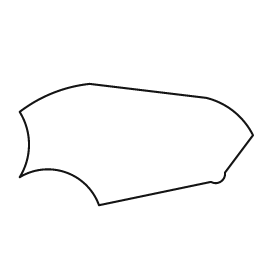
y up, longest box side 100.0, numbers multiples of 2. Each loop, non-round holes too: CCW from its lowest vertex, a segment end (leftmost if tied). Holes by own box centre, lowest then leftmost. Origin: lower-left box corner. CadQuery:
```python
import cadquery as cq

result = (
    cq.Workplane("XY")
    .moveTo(34.0, 0.0)
    .lineTo(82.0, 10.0)
    .threePointArc((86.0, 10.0), (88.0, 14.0))
    .lineTo(100.0, 30.0)
    .threePointArc((92.0, 40.0), (80.0, 46.0))
    .lineTo(30.0, 52.0)
    .threePointArc((14.0, 48.0), (0.0, 40.0))
    .threePointArc((4.0, 26.0), (0.0, 12.0))
    .threePointArc((20.0, 14.0), (34.0, 0.0))
    .close()
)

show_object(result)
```